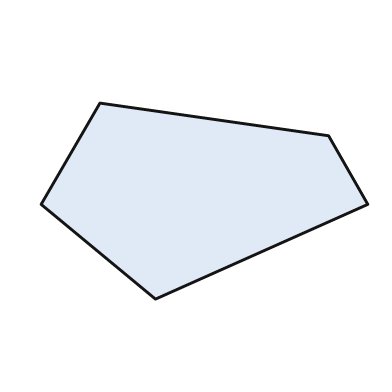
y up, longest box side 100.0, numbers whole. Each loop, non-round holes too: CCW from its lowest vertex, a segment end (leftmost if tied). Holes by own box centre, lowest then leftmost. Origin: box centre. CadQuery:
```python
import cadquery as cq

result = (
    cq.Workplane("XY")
    .moveTo(-15.0, -30.0)
    .lineTo(50.0, -1.0)
    .lineTo(38.0, 20.0)
    .lineTo(-32.0, 30.0)
    .lineTo(-50.0, -1.0)
    .close()
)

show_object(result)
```